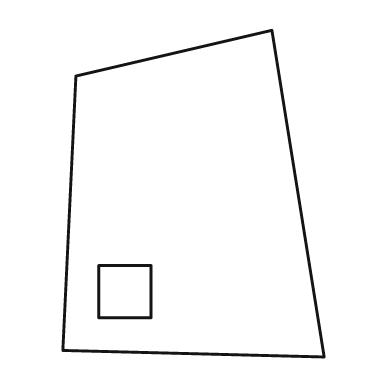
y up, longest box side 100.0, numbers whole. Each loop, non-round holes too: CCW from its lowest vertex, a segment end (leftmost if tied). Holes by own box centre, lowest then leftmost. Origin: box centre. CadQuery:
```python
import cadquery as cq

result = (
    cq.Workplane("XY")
    .moveTo(40.0, -50.0)
    .lineTo(24.0, 50.0)
    .lineTo(-36.0, 36.0)
    .lineTo(-40.0, -48.0)
    .close()
    .moveTo(-29.0, -38.0)
    .lineTo(-13.0, -38.0)
    .lineTo(-13.0, -22.0)
    .lineTo(-29.0, -22.0)
    .close()
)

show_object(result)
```